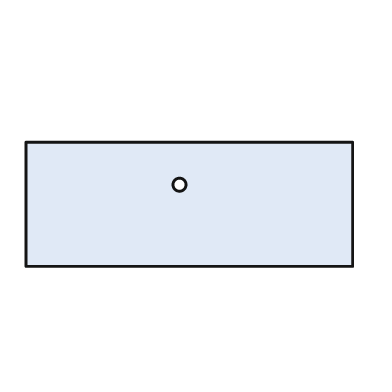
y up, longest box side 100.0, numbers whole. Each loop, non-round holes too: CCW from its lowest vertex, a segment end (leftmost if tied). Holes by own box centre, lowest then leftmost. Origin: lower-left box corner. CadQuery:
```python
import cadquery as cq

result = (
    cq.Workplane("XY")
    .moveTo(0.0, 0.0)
    .lineTo(100.0, 0.0)
    .lineTo(100.0, 38.0)
    .lineTo(0.0, 38.0)
    .close()
    .moveTo(47.0, 25.0)
    .circle(2.0)
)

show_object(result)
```